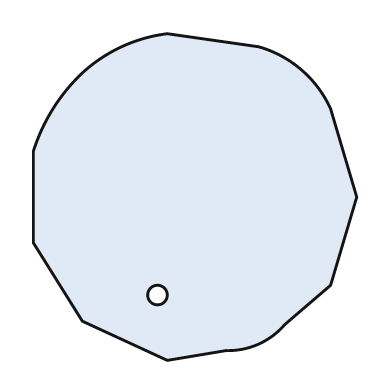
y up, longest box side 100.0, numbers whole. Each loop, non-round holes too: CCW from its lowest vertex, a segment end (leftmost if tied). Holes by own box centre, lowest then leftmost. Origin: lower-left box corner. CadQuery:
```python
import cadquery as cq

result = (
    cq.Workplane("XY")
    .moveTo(41.0, 0.0)
    .lineTo(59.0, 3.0)
    .threePointArc((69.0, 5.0), (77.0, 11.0))
    .lineTo(91.0, 23.0)
    .lineTo(99.0, 50.0)
    .lineTo(91.0, 77.0)
    .threePointArc((82.0, 89.0), (69.0, 96.0))
    .lineTo(41.0, 100.0)
    .threePointArc((27.0, 96.0), (15.0, 88.0))
    .threePointArc((6.0, 77.0), (0.0, 64.0))
    .lineTo(0.0, 36.0)
    .lineTo(15.0, 12.0)
    .close()
    .moveTo(38.0, 20.0)
    .circle(3.0)
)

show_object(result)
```